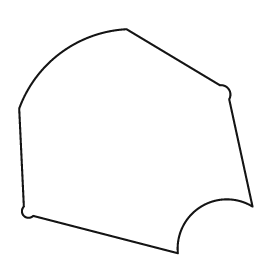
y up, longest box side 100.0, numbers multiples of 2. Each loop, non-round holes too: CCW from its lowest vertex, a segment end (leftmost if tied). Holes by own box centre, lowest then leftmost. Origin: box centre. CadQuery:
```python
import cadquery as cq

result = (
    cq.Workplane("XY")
    .moveTo(18.0, -48.0)
    .threePointArc((28.0, -28.0), (50.0, -28.0))
    .lineTo(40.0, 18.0)
    .threePointArc((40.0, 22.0), (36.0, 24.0))
    .lineTo(-4.0, 48.0)
    .threePointArc((-32.0, 38.0), (-50.0, 14.0))
    .lineTo(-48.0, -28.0)
    .threePointArc((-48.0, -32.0), (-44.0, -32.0))
    .close()
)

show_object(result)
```